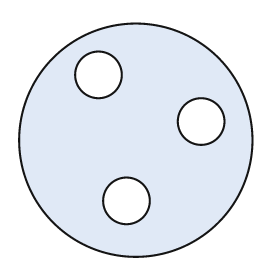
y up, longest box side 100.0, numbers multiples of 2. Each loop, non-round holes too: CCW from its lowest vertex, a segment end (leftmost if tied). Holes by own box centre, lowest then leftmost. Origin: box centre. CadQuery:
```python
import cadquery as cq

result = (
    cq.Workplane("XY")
    .moveTo(0.0, 0.0)
    .circle(50.0)
    .moveTo(-4.0, -26.0)
    .circle(10.0)
    .moveTo(28.0, 8.0)
    .circle(10.0)
    .moveTo(-16.0, 28.0)
    .circle(10.0)
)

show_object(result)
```